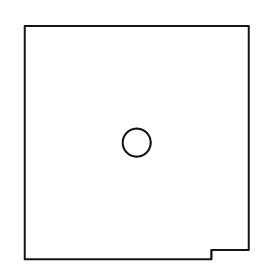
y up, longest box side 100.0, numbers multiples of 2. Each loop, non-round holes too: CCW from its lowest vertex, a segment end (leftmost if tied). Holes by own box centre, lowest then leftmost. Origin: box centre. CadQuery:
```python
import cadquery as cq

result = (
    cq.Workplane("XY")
    .moveTo(-48.0, -50.0)
    .lineTo(32.0, -50.0)
    .lineTo(32.0, -46.0)
    .lineTo(48.0, -46.0)
    .lineTo(48.0, 50.0)
    .lineTo(-48.0, 50.0)
    .close()
    .moveTo(0.0, 0.0)
    .circle(6.0)
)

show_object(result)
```